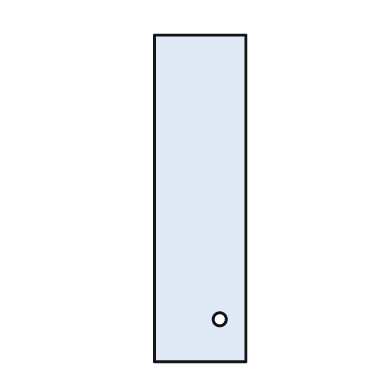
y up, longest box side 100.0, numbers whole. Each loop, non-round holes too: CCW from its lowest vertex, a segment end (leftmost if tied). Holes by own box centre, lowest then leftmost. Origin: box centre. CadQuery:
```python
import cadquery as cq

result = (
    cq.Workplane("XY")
    .moveTo(-14.0, -50.0)
    .lineTo(14.0, -50.0)
    .lineTo(14.0, 50.0)
    .lineTo(-14.0, 50.0)
    .close()
    .moveTo(6.0, -37.0)
    .circle(2.0)
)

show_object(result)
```